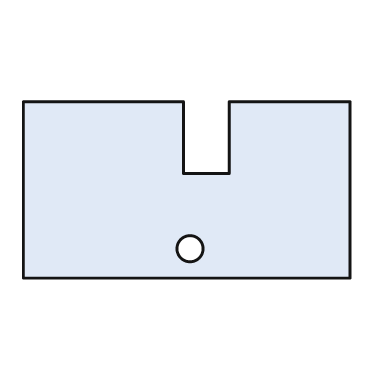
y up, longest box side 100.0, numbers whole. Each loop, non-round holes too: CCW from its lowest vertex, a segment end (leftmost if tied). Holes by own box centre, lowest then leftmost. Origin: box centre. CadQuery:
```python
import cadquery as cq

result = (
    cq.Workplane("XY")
    .moveTo(-50.0, -27.0)
    .lineTo(50.0, -27.0)
    .lineTo(50.0, 27.0)
    .lineTo(13.0, 27.0)
    .lineTo(13.0, 5.0)
    .lineTo(-1.0, 5.0)
    .lineTo(-1.0, 27.0)
    .lineTo(-50.0, 27.0)
    .close()
    .moveTo(1.0, -18.0)
    .circle(4.0)
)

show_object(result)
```